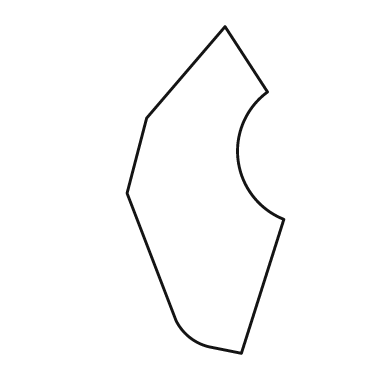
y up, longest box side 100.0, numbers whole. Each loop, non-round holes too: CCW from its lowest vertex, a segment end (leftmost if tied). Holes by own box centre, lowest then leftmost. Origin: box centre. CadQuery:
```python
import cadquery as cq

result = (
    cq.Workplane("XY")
    .moveTo(11.0, -50.0)
    .lineTo(24.0, -9.0)
    .threePointArc((10.0, 9.0), (19.0, 30.0))
    .lineTo(6.0, 50.0)
    .lineTo(-18.0, 22.0)
    .lineTo(-24.0, -1.0)
    .lineTo(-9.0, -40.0)
    .threePointArc((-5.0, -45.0), (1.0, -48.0))
    .close()
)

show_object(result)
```